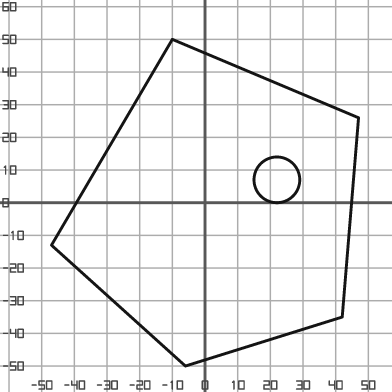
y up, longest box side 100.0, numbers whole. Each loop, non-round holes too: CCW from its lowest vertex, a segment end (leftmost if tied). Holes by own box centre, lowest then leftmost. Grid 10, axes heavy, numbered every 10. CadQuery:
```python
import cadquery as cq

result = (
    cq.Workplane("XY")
    .moveTo(-6.0, -50.0)
    .lineTo(42.0, -35.0)
    .lineTo(47.0, 26.0)
    .lineTo(-10.0, 50.0)
    .lineTo(-47.0, -13.0)
    .close()
    .moveTo(22.0, 7.0)
    .circle(7.0)
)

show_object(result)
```